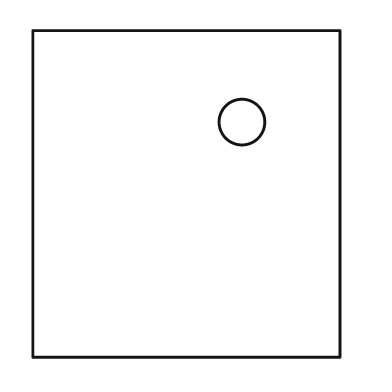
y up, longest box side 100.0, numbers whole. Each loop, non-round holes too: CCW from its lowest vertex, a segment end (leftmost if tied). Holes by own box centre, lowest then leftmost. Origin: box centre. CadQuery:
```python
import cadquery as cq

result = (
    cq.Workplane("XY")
    .moveTo(-47.0, -50.0)
    .lineTo(47.0, -50.0)
    .lineTo(47.0, 50.0)
    .lineTo(-47.0, 50.0)
    .close()
    .moveTo(17.0, 22.0)
    .circle(7.0)
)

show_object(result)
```